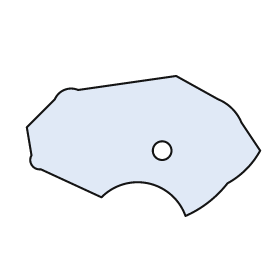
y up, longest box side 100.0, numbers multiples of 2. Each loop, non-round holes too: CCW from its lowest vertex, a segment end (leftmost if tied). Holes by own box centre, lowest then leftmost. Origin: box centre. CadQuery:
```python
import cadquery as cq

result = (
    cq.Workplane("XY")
    .moveTo(18.0, -30.0)
    .threePointArc((28.0, -24.0), (36.0, -16.0))
    .threePointArc((44.0, -10.0), (50.0, -2.0))
    .lineTo(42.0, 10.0)
    .threePointArc((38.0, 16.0), (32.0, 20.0))
    .lineTo(14.0, 30.0)
    .lineTo(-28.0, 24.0)
    .threePointArc((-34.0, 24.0), (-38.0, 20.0))
    .lineTo(-50.0, 8.0)
    .lineTo(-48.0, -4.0)
    .threePointArc((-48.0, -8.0), (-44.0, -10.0))
    .lineTo(-18.0, -22.0)
    .threePointArc((2.0, -16.0), (18.0, -30.0))
    .close()
    .moveTo(8.0, -2.0)
    .circle(4.0)
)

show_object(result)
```